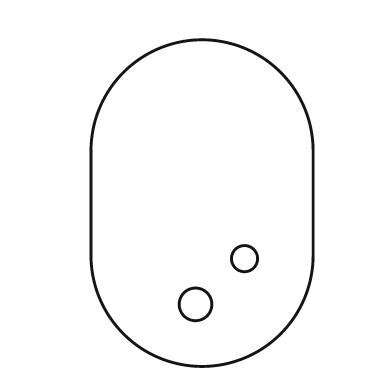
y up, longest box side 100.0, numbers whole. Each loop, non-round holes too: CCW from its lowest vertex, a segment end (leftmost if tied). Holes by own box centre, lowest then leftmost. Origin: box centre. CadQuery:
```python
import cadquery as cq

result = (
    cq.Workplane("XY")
    .moveTo(-34.0, -16.0)
    .threePointArc((0.0, -50.0), (34.0, -16.0))
    .lineTo(34.0, 16.0)
    .threePointArc((0.0, 50.0), (-34.0, 16.0))
    .close()
    .moveTo(-2.0, -31.0)
    .circle(5.0)
    .moveTo(13.0, -17.0)
    .circle(4.0)
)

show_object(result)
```